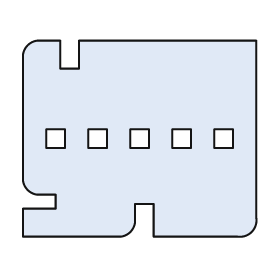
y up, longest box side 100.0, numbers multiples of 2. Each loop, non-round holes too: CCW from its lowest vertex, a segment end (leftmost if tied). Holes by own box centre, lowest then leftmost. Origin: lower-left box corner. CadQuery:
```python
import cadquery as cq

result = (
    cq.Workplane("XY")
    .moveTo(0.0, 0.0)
    .lineTo(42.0, 0.0)
    .threePointArc((46.0, 2.0), (48.0, 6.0))
    .lineTo(48.0, 14.0)
    .lineTo(56.0, 14.0)
    .lineTo(56.0, 0.0)
    .lineTo(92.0, 0.0)
    .threePointArc((98.0, 2.0), (100.0, 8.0))
    .lineTo(100.0, 84.0)
    .lineTo(24.0, 84.0)
    .lineTo(24.0, 72.0)
    .lineTo(16.0, 72.0)
    .lineTo(16.0, 84.0)
    .lineTo(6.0, 84.0)
    .threePointArc((2.0, 82.0), (0.0, 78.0))
    .lineTo(0.0, 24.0)
    .threePointArc((2.0, 20.0), (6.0, 18.0))
    .lineTo(14.0, 18.0)
    .lineTo(14.0, 12.0)
    .lineTo(0.0, 12.0)
    .close()
    .moveTo(10.0, 38.0)
    .lineTo(18.0, 38.0)
    .lineTo(18.0, 46.0)
    .lineTo(10.0, 46.0)
    .close()
    .moveTo(28.0, 38.0)
    .lineTo(36.0, 38.0)
    .lineTo(36.0, 46.0)
    .lineTo(28.0, 46.0)
    .close()
    .moveTo(46.0, 38.0)
    .lineTo(54.0, 38.0)
    .lineTo(54.0, 46.0)
    .lineTo(46.0, 46.0)
    .close()
    .moveTo(64.0, 38.0)
    .lineTo(72.0, 38.0)
    .lineTo(72.0, 46.0)
    .lineTo(64.0, 46.0)
    .close()
    .moveTo(82.0, 38.0)
    .lineTo(90.0, 38.0)
    .lineTo(90.0, 46.0)
    .lineTo(82.0, 46.0)
    .close()
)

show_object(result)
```